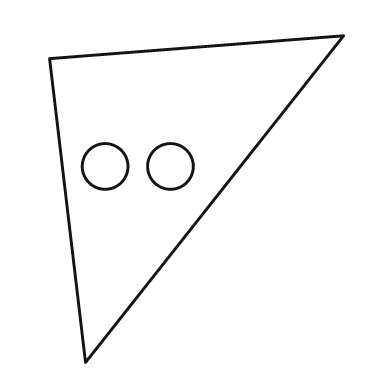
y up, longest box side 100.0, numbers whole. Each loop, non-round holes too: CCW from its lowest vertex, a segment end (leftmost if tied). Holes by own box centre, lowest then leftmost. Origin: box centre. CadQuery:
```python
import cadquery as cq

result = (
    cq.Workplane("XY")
    .moveTo(-34.0, -50.0)
    .lineTo(45.0, 50.0)
    .lineTo(-45.0, 43.0)
    .close()
    .moveTo(-28.0, 10.0)
    .circle(7.0)
    .moveTo(-8.0, 10.0)
    .circle(7.0)
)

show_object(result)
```